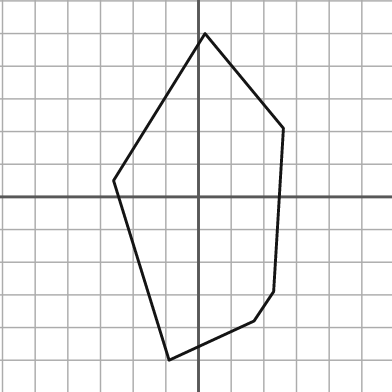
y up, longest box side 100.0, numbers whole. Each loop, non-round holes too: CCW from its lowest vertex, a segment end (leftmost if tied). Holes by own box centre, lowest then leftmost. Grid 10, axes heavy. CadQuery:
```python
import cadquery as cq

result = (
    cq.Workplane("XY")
    .moveTo(-9.0, -50.0)
    .lineTo(17.0, -38.0)
    .lineTo(23.0, -29.0)
    .lineTo(26.0, 21.0)
    .lineTo(2.0, 50.0)
    .lineTo(-26.0, 5.0)
    .close()
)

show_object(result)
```